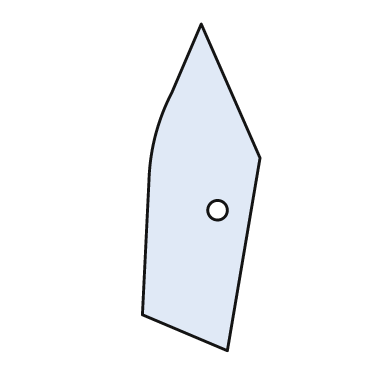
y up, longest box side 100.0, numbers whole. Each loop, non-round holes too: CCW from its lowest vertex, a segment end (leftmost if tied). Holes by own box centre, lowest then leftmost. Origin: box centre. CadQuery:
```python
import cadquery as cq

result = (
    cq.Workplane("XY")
    .moveTo(8.0, -50.0)
    .lineTo(18.0, 9.0)
    .lineTo(0.0, 50.0)
    .lineTo(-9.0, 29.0)
    .threePointArc((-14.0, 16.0), (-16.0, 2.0))
    .lineTo(-18.0, -39.0)
    .close()
    .moveTo(5.0, -7.0)
    .circle(3.0)
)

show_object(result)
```